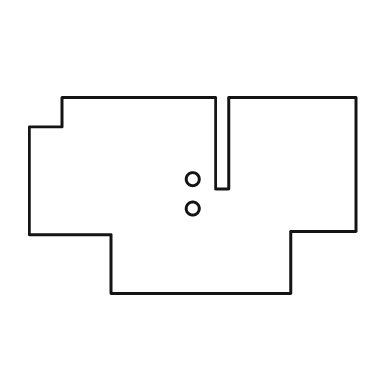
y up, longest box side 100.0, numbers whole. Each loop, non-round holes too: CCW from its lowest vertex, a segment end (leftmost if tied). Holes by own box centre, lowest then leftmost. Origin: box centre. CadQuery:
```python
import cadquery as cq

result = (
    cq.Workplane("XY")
    .moveTo(-25.0, -30.0)
    .lineTo(30.0, -30.0)
    .lineTo(30.0, -11.0)
    .lineTo(50.0, -11.0)
    .lineTo(50.0, 30.0)
    .lineTo(11.0, 30.0)
    .lineTo(11.0, 2.0)
    .lineTo(7.0, 2.0)
    .lineTo(7.0, 30.0)
    .lineTo(-40.0, 30.0)
    .lineTo(-40.0, 21.0)
    .lineTo(-50.0, 21.0)
    .lineTo(-50.0, -12.0)
    .lineTo(-25.0, -12.0)
    .close()
    .moveTo(0.0, -4.0)
    .circle(2.0)
    .moveTo(0.0, 5.0)
    .circle(2.0)
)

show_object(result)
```